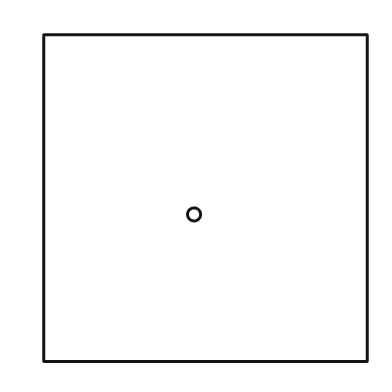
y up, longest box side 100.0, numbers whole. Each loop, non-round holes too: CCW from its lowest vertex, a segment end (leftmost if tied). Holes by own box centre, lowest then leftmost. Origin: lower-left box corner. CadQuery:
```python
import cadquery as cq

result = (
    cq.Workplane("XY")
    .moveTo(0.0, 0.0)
    .lineTo(99.0, 0.0)
    .lineTo(99.0, 100.0)
    .lineTo(0.0, 100.0)
    .close()
    .moveTo(46.0, 45.0)
    .circle(2.0)
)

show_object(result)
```